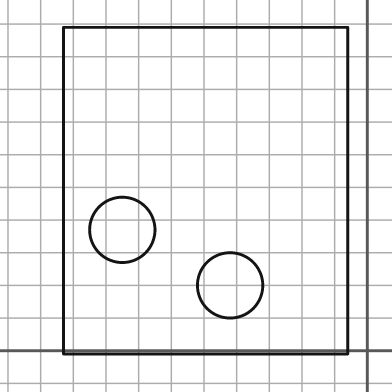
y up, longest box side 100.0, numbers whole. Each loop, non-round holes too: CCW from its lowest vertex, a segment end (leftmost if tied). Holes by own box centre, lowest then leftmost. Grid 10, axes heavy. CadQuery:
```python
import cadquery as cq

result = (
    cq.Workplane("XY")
    .moveTo(-93.0, -1.0)
    .lineTo(-6.0, -1.0)
    .lineTo(-6.0, 99.0)
    .lineTo(-93.0, 99.0)
    .close()
    .moveTo(-42.0, 20.0)
    .circle(10.0)
    .moveTo(-75.0, 37.0)
    .circle(10.0)
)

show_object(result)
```